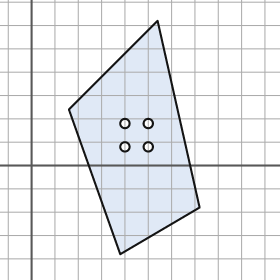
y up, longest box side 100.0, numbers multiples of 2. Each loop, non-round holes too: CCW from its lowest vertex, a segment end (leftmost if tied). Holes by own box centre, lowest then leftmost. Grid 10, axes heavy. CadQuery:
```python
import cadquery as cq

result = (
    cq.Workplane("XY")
    .moveTo(38.0, -38.0)
    .lineTo(72.0, -18.0)
    .lineTo(54.0, 62.0)
    .lineTo(16.0, 24.0)
    .close()
    .moveTo(40.0, 8.0)
    .circle(2.0)
    .moveTo(50.0, 8.0)
    .circle(2.0)
    .moveTo(40.0, 18.0)
    .circle(2.0)
    .moveTo(50.0, 18.0)
    .circle(2.0)
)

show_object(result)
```